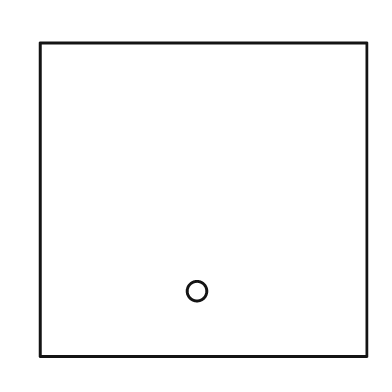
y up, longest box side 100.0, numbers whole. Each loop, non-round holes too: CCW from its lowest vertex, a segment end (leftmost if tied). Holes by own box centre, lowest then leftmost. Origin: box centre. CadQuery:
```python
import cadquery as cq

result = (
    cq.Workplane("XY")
    .moveTo(-50.0, -48.0)
    .lineTo(50.0, -48.0)
    .lineTo(50.0, 48.0)
    .lineTo(-50.0, 48.0)
    .close()
    .moveTo(-2.0, -28.0)
    .circle(3.0)
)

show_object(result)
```